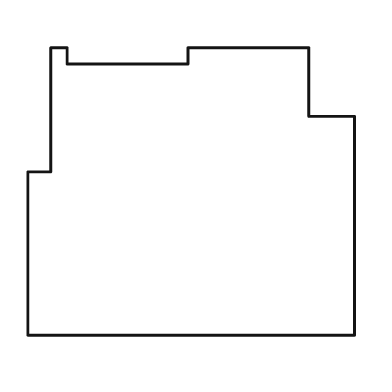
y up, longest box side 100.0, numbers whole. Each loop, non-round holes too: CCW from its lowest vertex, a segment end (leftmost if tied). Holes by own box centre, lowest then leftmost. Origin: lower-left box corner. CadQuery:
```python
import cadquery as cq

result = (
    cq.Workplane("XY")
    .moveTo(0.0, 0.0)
    .lineTo(100.0, 0.0)
    .lineTo(100.0, 67.0)
    .lineTo(86.0, 67.0)
    .lineTo(86.0, 88.0)
    .lineTo(49.0, 88.0)
    .lineTo(49.0, 83.0)
    .lineTo(12.0, 83.0)
    .lineTo(12.0, 88.0)
    .lineTo(7.0, 88.0)
    .lineTo(7.0, 50.0)
    .lineTo(0.0, 50.0)
    .close()
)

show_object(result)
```